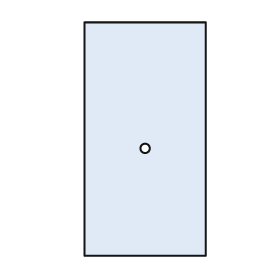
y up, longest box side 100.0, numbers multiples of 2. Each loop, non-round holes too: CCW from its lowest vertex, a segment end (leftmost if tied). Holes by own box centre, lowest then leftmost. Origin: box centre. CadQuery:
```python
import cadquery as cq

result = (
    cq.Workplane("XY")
    .moveTo(-26.0, -50.0)
    .lineTo(26.0, -50.0)
    .lineTo(26.0, 50.0)
    .lineTo(-26.0, 50.0)
    .close()
    .moveTo(0.0, -4.0)
    .circle(2.0)
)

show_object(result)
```